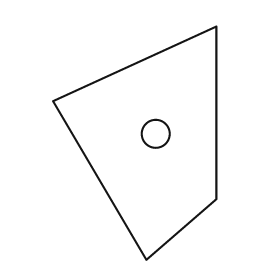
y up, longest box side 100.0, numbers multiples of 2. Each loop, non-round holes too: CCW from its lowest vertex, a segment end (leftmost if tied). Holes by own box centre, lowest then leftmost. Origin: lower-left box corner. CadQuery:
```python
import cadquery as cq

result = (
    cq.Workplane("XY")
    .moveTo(40.0, 0.0)
    .lineTo(70.0, 26.0)
    .lineTo(70.0, 100.0)
    .lineTo(0.0, 68.0)
    .close()
    .moveTo(44.0, 54.0)
    .circle(6.0)
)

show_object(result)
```